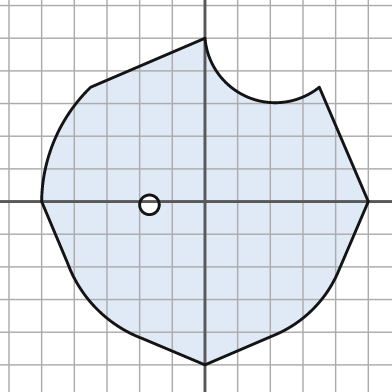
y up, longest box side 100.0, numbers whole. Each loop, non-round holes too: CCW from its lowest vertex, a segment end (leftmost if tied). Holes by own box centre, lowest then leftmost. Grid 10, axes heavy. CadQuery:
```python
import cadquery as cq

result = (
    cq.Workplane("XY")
    .moveTo(0.0, -50.0)
    .lineTo(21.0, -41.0)
    .threePointArc((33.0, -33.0), (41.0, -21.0))
    .lineTo(50.0, 0.0)
    .lineTo(35.0, 35.0)
    .threePointArc((13.0, 32.0), (0.0, 50.0))
    .lineTo(-35.0, 35.0)
    .threePointArc((-46.0, 19.0), (-50.0, 0.0))
    .lineTo(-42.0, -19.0)
    .threePointArc((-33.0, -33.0), (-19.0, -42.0))
    .close()
    .moveTo(-17.0, -1.0)
    .circle(3.0)
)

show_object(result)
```